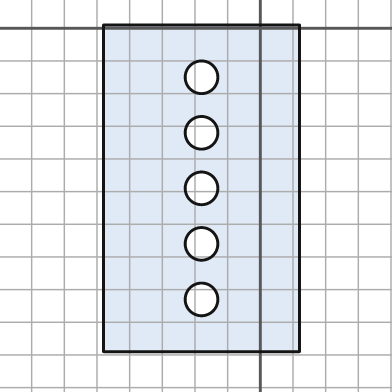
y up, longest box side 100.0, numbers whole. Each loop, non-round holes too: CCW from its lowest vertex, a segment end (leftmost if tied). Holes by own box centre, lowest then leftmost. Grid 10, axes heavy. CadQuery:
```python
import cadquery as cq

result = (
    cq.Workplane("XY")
    .moveTo(-48.0, -99.0)
    .lineTo(12.0, -99.0)
    .lineTo(12.0, 1.0)
    .lineTo(-48.0, 1.0)
    .close()
    .moveTo(-18.0, -83.0)
    .circle(5.0)
    .moveTo(-18.0, -66.0)
    .circle(5.0)
    .moveTo(-18.0, -49.0)
    .circle(5.0)
    .moveTo(-18.0, -32.0)
    .circle(5.0)
    .moveTo(-18.0, -15.0)
    .circle(5.0)
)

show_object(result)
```